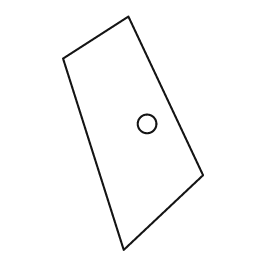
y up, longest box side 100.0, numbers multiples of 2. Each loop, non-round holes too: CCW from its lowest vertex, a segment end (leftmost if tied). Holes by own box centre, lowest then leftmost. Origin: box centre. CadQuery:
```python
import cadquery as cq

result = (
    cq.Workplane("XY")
    .moveTo(-4.0, -50.0)
    .lineTo(30.0, -18.0)
    .lineTo(-2.0, 50.0)
    .lineTo(-30.0, 32.0)
    .close()
    .moveTo(6.0, 4.0)
    .circle(4.0)
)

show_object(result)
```